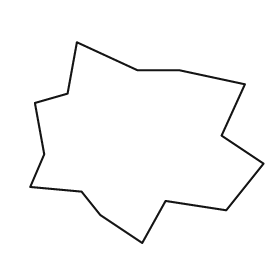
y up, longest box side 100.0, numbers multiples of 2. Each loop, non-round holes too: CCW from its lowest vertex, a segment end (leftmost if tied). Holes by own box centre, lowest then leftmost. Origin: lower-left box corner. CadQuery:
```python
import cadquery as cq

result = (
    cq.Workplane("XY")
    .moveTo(48.0, 0.0)
    .lineTo(58.0, 18.0)
    .lineTo(84.0, 14.0)
    .lineTo(100.0, 34.0)
    .lineTo(82.0, 46.0)
    .lineTo(92.0, 68.0)
    .lineTo(64.0, 74.0)
    .lineTo(46.0, 74.0)
    .lineTo(20.0, 86.0)
    .lineTo(16.0, 64.0)
    .lineTo(2.0, 60.0)
    .lineTo(6.0, 38.0)
    .lineTo(0.0, 24.0)
    .lineTo(22.0, 22.0)
    .lineTo(30.0, 12.0)
    .close()
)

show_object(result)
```